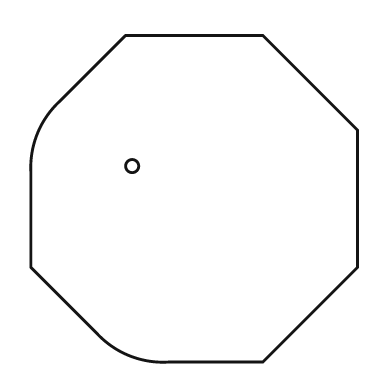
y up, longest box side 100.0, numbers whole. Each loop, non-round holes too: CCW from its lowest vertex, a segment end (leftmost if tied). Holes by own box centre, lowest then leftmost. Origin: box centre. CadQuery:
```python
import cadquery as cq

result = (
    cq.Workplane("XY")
    .moveTo(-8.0, -50.0)
    .lineTo(21.0, -50.0)
    .lineTo(50.0, -21.0)
    .lineTo(50.0, 21.0)
    .lineTo(21.0, 50.0)
    .lineTo(-21.0, 50.0)
    .lineTo(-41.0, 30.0)
    .threePointArc((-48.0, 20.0), (-50.0, 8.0))
    .lineTo(-50.0, -21.0)
    .lineTo(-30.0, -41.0)
    .threePointArc((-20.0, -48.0), (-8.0, -50.0))
    .close()
    .moveTo(-19.0, 10.0)
    .circle(2.0)
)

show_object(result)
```